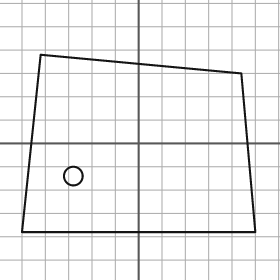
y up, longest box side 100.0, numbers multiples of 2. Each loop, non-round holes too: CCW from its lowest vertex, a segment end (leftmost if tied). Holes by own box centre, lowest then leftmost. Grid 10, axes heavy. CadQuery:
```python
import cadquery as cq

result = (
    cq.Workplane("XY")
    .moveTo(-50.0, -38.0)
    .lineTo(50.0, -38.0)
    .lineTo(44.0, 30.0)
    .lineTo(-42.0, 38.0)
    .close()
    .moveTo(-28.0, -14.0)
    .circle(4.0)
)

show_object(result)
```